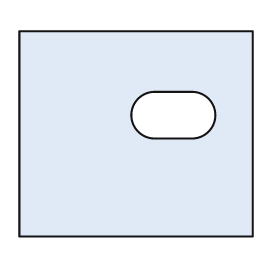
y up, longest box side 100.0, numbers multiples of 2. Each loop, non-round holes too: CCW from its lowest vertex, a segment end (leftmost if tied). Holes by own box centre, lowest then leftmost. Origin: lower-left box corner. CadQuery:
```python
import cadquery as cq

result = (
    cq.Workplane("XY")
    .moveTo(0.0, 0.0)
    .lineTo(100.0, 0.0)
    .lineTo(100.0, 88.0)
    .lineTo(0.0, 88.0)
    .close()
    .moveTo(58.0, 42.0)
    .lineTo(74.0, 42.0)
    .threePointArc((84.0, 52.0), (74.0, 62.0))
    .lineTo(58.0, 62.0)
    .threePointArc((48.0, 52.0), (58.0, 42.0))
    .close()
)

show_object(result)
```